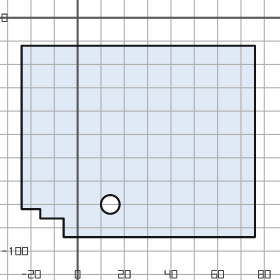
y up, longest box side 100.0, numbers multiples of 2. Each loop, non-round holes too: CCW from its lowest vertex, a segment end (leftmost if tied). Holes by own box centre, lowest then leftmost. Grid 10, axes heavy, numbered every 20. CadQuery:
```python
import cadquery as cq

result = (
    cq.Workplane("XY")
    .moveTo(-6.0, -94.0)
    .lineTo(76.0, -94.0)
    .lineTo(76.0, -12.0)
    .lineTo(-24.0, -12.0)
    .lineTo(-24.0, -82.0)
    .lineTo(-16.0, -82.0)
    .lineTo(-16.0, -86.0)
    .lineTo(-6.0, -86.0)
    .close()
    .moveTo(14.0, -80.0)
    .circle(4.0)
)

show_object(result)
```